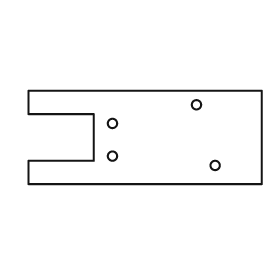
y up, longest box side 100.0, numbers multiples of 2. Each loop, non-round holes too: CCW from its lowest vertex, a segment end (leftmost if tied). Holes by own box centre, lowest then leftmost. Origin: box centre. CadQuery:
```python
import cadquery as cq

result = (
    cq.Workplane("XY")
    .moveTo(-50.0, -20.0)
    .lineTo(50.0, -20.0)
    .lineTo(50.0, 20.0)
    .lineTo(-50.0, 20.0)
    .lineTo(-50.0, 10.0)
    .lineTo(-22.0, 10.0)
    .lineTo(-22.0, -10.0)
    .lineTo(-50.0, -10.0)
    .close()
    .moveTo(30.0, -12.0)
    .circle(2.0)
    .moveTo(-14.0, -8.0)
    .circle(2.0)
    .moveTo(-14.0, 6.0)
    .circle(2.0)
    .moveTo(22.0, 14.0)
    .circle(2.0)
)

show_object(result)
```